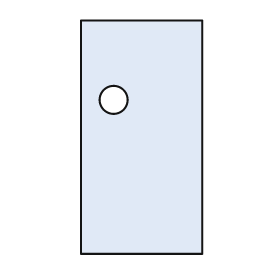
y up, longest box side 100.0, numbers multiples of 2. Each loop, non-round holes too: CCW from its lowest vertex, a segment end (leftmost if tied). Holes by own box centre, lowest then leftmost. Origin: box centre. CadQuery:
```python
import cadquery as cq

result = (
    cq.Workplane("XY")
    .moveTo(-26.0, -50.0)
    .lineTo(26.0, -50.0)
    .lineTo(26.0, 50.0)
    .lineTo(-26.0, 50.0)
    .close()
    .moveTo(-12.0, 16.0)
    .circle(6.0)
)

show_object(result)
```